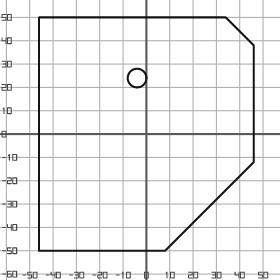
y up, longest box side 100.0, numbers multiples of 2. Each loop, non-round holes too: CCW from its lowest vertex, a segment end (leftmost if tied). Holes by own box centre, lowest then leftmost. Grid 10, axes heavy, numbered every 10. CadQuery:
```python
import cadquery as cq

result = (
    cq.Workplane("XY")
    .moveTo(-46.0, -50.0)
    .lineTo(8.0, -50.0)
    .lineTo(46.0, -12.0)
    .lineTo(46.0, 38.0)
    .lineTo(34.0, 50.0)
    .lineTo(-46.0, 50.0)
    .close()
    .moveTo(-4.0, 24.0)
    .circle(4.0)
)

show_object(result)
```